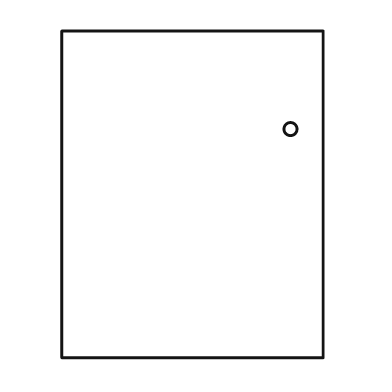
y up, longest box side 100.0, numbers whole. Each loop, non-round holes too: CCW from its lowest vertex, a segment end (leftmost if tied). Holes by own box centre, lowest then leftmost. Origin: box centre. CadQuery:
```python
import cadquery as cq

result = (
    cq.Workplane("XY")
    .moveTo(-40.0, -50.0)
    .lineTo(40.0, -50.0)
    .lineTo(40.0, 50.0)
    .lineTo(-40.0, 50.0)
    .close()
    .moveTo(30.0, 20.0)
    .circle(2.0)
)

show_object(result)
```